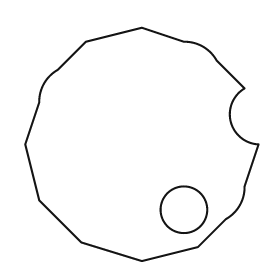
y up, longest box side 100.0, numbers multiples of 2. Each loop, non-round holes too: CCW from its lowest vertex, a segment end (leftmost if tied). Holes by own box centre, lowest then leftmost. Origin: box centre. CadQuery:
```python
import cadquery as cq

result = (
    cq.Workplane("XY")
    .moveTo(0.0, -50.0)
    .lineTo(24.0, -44.0)
    .lineTo(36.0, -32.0)
    .threePointArc((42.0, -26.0), (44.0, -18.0))
    .lineTo(50.0, 0.0)
    .threePointArc((38.0, 10.0), (44.0, 24.0))
    .lineTo(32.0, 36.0)
    .threePointArc((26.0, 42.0), (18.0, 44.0))
    .lineTo(0.0, 50.0)
    .lineTo(-24.0, 44.0)
    .lineTo(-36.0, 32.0)
    .threePointArc((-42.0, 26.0), (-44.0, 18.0))
    .lineTo(-50.0, 0.0)
    .lineTo(-44.0, -24.0)
    .lineTo(-26.0, -42.0)
    .close()
    .moveTo(18.0, -28.0)
    .circle(10.0)
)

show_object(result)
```